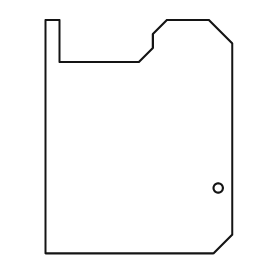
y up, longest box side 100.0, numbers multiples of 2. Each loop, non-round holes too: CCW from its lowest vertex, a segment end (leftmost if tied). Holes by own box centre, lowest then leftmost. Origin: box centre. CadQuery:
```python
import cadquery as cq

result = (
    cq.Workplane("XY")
    .moveTo(-40.0, -50.0)
    .lineTo(32.0, -50.0)
    .lineTo(40.0, -42.0)
    .lineTo(40.0, 40.0)
    .lineTo(30.0, 50.0)
    .lineTo(12.0, 50.0)
    .lineTo(6.0, 44.0)
    .lineTo(6.0, 38.0)
    .lineTo(0.0, 32.0)
    .lineTo(-34.0, 32.0)
    .lineTo(-34.0, 50.0)
    .lineTo(-40.0, 50.0)
    .close()
    .moveTo(34.0, -22.0)
    .circle(2.0)
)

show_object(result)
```